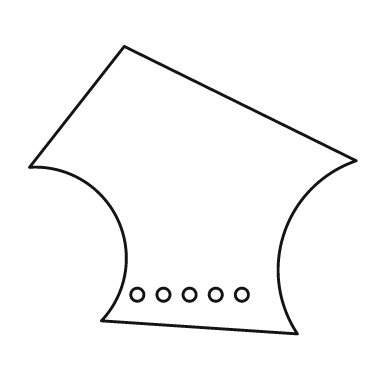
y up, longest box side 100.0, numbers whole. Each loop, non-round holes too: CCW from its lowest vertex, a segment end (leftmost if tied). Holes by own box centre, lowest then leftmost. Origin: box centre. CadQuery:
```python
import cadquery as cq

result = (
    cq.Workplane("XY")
    .moveTo(32.0, -44.0)
    .threePointArc((28.0, -13.0), (50.0, 9.0))
    .lineTo(-21.0, 44.0)
    .lineTo(-50.0, 7.0)
    .threePointArc((-23.0, -9.0), (-28.0, -40.0))
    .close()
    .moveTo(-17.0, -32.0)
    .circle(2.0)
    .moveTo(-9.0, -32.0)
    .circle(2.0)
    .moveTo(-1.0, -32.0)
    .circle(2.0)
    .moveTo(7.0, -32.0)
    .circle(2.0)
    .moveTo(15.0, -32.0)
    .circle(2.0)
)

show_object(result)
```